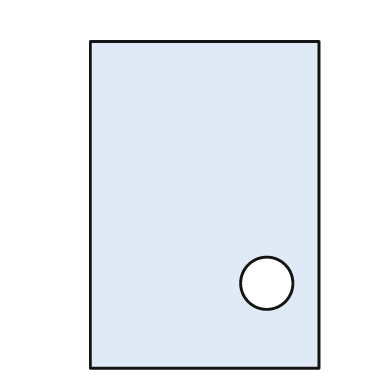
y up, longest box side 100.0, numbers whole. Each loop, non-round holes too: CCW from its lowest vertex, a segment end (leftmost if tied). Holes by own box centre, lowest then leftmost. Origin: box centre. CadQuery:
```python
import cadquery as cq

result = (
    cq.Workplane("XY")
    .moveTo(-35.0, -50.0)
    .lineTo(35.0, -50.0)
    .lineTo(35.0, 50.0)
    .lineTo(-35.0, 50.0)
    .close()
    .moveTo(19.0, -24.0)
    .circle(8.0)
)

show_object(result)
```